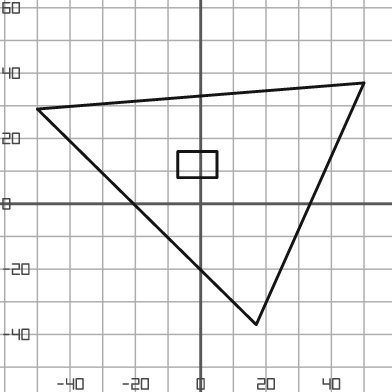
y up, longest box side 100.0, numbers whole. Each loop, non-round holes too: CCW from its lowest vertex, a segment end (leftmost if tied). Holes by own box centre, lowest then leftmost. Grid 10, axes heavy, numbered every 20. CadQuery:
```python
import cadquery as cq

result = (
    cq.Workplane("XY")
    .moveTo(17.0, -37.0)
    .lineTo(50.0, 37.0)
    .lineTo(-50.0, 29.0)
    .close()
    .moveTo(-7.0, 8.0)
    .lineTo(5.0, 8.0)
    .lineTo(5.0, 16.0)
    .lineTo(-7.0, 16.0)
    .close()
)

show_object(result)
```